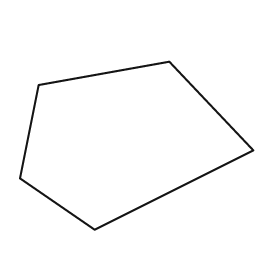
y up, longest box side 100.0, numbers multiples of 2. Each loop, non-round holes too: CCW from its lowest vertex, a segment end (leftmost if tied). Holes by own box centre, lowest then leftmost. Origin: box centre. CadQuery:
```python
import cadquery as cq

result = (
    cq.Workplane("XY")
    .moveTo(-18.0, -36.0)
    .lineTo(50.0, -2.0)
    .lineTo(14.0, 36.0)
    .lineTo(-42.0, 26.0)
    .lineTo(-50.0, -14.0)
    .close()
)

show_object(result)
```